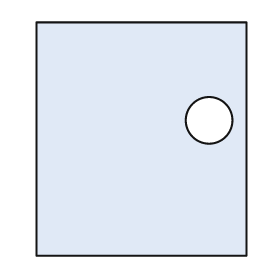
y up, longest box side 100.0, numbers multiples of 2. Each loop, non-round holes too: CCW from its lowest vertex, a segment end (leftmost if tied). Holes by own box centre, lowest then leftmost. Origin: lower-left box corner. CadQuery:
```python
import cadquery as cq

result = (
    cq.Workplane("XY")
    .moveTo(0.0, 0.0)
    .lineTo(90.0, 0.0)
    .lineTo(90.0, 100.0)
    .lineTo(0.0, 100.0)
    .close()
    .moveTo(74.0, 58.0)
    .circle(10.0)
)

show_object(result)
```